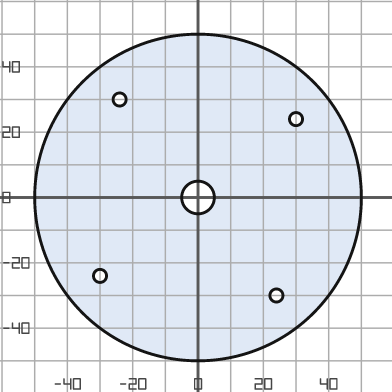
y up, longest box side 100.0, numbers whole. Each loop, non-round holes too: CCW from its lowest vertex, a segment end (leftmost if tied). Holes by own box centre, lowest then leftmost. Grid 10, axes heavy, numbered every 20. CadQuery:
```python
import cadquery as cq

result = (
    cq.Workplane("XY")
    .moveTo(0.0, 0.0)
    .circle(50.0)
    .moveTo(24.0, -30.0)
    .circle(2.0)
    .moveTo(-30.0, -24.0)
    .circle(2.0)
    .moveTo(0.0, 0.0)
    .circle(5.0)
    .moveTo(30.0, 24.0)
    .circle(2.0)
    .moveTo(-24.0, 30.0)
    .circle(2.0)
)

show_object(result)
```